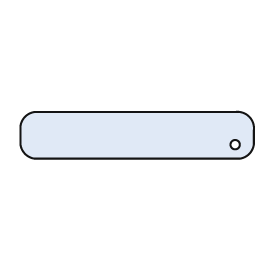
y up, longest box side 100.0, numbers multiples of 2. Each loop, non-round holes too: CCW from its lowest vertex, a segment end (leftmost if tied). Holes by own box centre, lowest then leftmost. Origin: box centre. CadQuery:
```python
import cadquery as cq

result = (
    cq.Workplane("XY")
    .moveTo(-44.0, -10.0)
    .lineTo(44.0, -10.0)
    .threePointArc((48.0, -8.0), (50.0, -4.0))
    .lineTo(50.0, 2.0)
    .threePointArc((48.0, 8.0), (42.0, 10.0))
    .lineTo(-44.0, 10.0)
    .threePointArc((-48.0, 8.0), (-50.0, 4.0))
    .lineTo(-50.0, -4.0)
    .threePointArc((-48.0, -8.0), (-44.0, -10.0))
    .close()
    .moveTo(42.0, -4.0)
    .circle(2.0)
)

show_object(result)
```